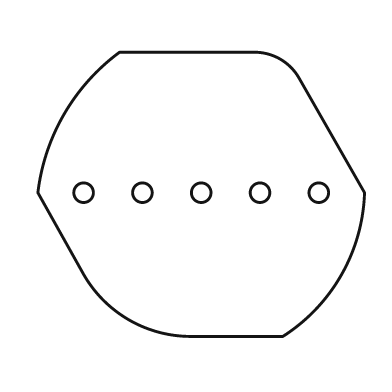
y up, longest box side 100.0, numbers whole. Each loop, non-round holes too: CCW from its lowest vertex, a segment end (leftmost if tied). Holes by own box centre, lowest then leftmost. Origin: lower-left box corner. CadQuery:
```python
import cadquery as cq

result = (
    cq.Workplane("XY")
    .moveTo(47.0, 0.0)
    .lineTo(75.0, 0.0)
    .threePointArc((93.0, 19.0), (100.0, 44.0))
    .lineTo(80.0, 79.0)
    .threePointArc((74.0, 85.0), (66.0, 87.0))
    .lineTo(25.0, 87.0)
    .threePointArc((8.0, 68.0), (0.0, 44.0))
    .lineTo(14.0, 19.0)
    .threePointArc((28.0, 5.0), (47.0, 0.0))
    .close()
    .moveTo(14.0, 44.0)
    .circle(3.0)
    .moveTo(32.0, 44.0)
    .circle(3.0)
    .moveTo(50.0, 44.0)
    .circle(3.0)
    .moveTo(68.0, 44.0)
    .circle(3.0)
    .moveTo(86.0, 44.0)
    .circle(3.0)
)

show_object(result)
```